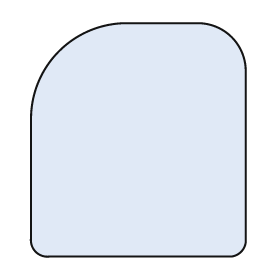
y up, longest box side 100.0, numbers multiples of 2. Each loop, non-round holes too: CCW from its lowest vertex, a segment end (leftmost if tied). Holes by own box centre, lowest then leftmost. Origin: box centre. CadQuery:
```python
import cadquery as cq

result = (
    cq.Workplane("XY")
    .moveTo(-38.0, -50.0)
    .lineTo(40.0, -50.0)
    .threePointArc((44.0, -48.0), (46.0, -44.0))
    .lineTo(46.0, 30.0)
    .threePointArc((40.0, 44.0), (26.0, 50.0))
    .lineTo(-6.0, 50.0)
    .threePointArc((-34.0, 38.0), (-46.0, 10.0))
    .lineTo(-46.0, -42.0)
    .threePointArc((-44.0, -48.0), (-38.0, -50.0))
    .close()
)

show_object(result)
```